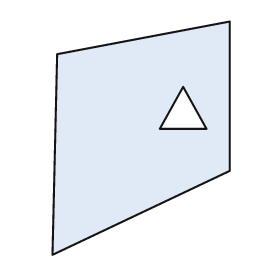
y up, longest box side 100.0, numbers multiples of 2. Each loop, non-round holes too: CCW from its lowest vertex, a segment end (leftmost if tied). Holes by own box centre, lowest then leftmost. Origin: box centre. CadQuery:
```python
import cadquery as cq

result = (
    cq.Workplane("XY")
    .moveTo(-38.0, -50.0)
    .lineTo(38.0, -14.0)
    .lineTo(38.0, 50.0)
    .lineTo(-36.0, 36.0)
    .close()
    .moveTo(8.0, 4.0)
    .lineTo(28.0, 4.0)
    .lineTo(18.0, 22.0)
    .close()
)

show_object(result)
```